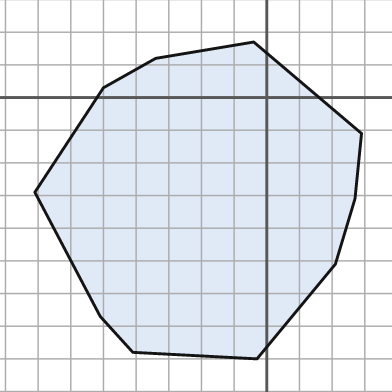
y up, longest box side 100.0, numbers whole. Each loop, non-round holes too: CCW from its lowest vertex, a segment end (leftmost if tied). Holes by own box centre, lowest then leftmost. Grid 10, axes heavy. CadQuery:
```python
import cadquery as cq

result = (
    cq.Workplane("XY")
    .moveTo(-3.0, -80.0)
    .lineTo(21.0, -51.0)
    .lineTo(27.0, -31.0)
    .lineTo(29.0, -11.0)
    .lineTo(-4.0, 17.0)
    .lineTo(-34.0, 12.0)
    .lineTo(-50.0, 3.0)
    .lineTo(-71.0, -29.0)
    .lineTo(-51.0, -67.0)
    .lineTo(-41.0, -78.0)
    .close()
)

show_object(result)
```